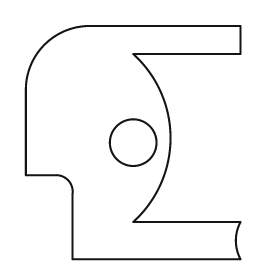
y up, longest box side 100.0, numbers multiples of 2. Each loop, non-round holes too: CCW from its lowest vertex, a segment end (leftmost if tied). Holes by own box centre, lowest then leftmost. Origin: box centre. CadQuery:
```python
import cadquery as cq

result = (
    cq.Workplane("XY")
    .moveTo(-26.0, -50.0)
    .lineTo(46.0, -50.0)
    .threePointArc((44.0, -42.0), (46.0, -34.0))
    .lineTo(0.0, -34.0)
    .threePointArc((16.0, 2.0), (0.0, 38.0))
    .lineTo(46.0, 38.0)
    .lineTo(46.0, 50.0)
    .lineTo(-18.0, 50.0)
    .threePointArc((-38.0, 42.0), (-46.0, 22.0))
    .lineTo(-46.0, -14.0)
    .lineTo(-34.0, -14.0)
    .threePointArc((-28.0, -16.0), (-26.0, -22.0))
    .close()
    .moveTo(0.0, 0.0)
    .circle(10.0)
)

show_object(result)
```